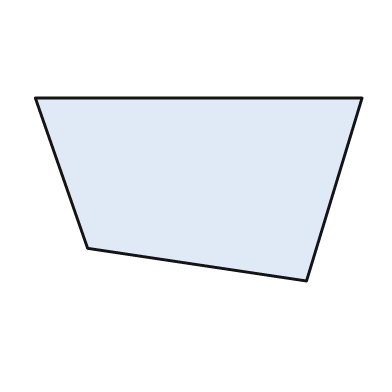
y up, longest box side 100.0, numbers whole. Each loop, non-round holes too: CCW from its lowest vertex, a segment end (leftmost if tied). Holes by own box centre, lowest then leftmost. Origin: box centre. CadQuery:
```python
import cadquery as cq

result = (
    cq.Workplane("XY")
    .moveTo(33.0, -28.0)
    .lineTo(50.0, 28.0)
    .lineTo(-50.0, 28.0)
    .lineTo(-34.0, -18.0)
    .close()
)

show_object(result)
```